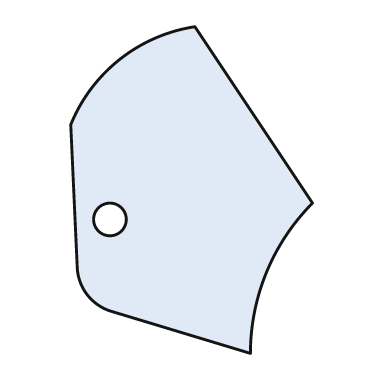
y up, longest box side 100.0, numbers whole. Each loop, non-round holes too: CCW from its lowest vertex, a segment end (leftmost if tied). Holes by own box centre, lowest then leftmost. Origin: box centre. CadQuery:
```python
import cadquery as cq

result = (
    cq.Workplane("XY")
    .moveTo(18.0, -50.0)
    .threePointArc((23.0, -25.0), (37.0, -4.0))
    .lineTo(1.0, 50.0)
    .threePointArc((-22.0, 40.0), (-37.0, 20.0))
    .lineTo(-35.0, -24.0)
    .threePointArc((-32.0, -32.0), (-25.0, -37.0))
    .close()
    .moveTo(-25.0, -9.0)
    .circle(5.0)
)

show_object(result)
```